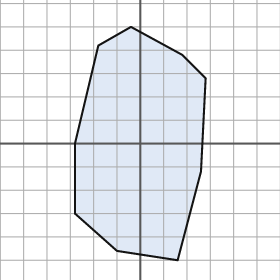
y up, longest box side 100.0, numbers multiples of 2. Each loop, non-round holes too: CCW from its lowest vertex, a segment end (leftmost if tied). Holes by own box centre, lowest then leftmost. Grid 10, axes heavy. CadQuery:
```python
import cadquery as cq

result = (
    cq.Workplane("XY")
    .moveTo(16.0, -50.0)
    .lineTo(26.0, -12.0)
    .lineTo(28.0, 28.0)
    .lineTo(18.0, 38.0)
    .lineTo(-4.0, 50.0)
    .lineTo(-18.0, 42.0)
    .lineTo(-28.0, 0.0)
    .lineTo(-28.0, -30.0)
    .lineTo(-10.0, -46.0)
    .close()
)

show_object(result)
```